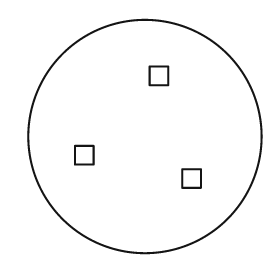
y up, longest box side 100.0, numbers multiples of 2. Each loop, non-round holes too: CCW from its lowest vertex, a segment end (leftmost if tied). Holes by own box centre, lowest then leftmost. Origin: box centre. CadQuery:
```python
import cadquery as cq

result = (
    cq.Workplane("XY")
    .moveTo(0.0, 0.0)
    .circle(50.0)
    .moveTo(16.0, -22.0)
    .lineTo(24.0, -22.0)
    .lineTo(24.0, -14.0)
    .lineTo(16.0, -14.0)
    .close()
    .moveTo(-30.0, -12.0)
    .lineTo(-22.0, -12.0)
    .lineTo(-22.0, -4.0)
    .lineTo(-30.0, -4.0)
    .close()
    .moveTo(2.0, 22.0)
    .lineTo(10.0, 22.0)
    .lineTo(10.0, 30.0)
    .lineTo(2.0, 30.0)
    .close()
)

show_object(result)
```